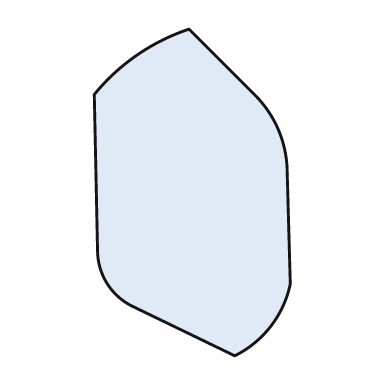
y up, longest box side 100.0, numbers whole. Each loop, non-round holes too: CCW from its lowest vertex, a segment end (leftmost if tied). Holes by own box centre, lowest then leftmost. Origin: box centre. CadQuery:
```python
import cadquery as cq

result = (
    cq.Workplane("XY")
    .moveTo(13.0, -50.0)
    .threePointArc((24.0, -41.0), (30.0, -28.0))
    .lineTo(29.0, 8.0)
    .threePointArc((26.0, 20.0), (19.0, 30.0))
    .lineTo(-1.0, 50.0)
    .threePointArc((-17.0, 42.0), (-30.0, 30.0))
    .lineTo(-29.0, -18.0)
    .threePointArc((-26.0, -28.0), (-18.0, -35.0))
    .close()
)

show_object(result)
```